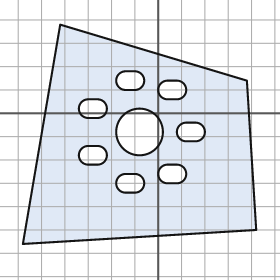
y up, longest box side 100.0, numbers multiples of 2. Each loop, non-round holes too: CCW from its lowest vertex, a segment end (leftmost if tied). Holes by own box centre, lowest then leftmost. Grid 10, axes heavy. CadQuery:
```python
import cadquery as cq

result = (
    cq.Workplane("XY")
    .moveTo(-58.0, -56.0)
    .lineTo(42.0, -50.0)
    .lineTo(38.0, 14.0)
    .lineTo(-42.0, 38.0)
    .close()
    .moveTo(-14.0, -34.0)
    .lineTo(-10.0, -34.0)
    .threePointArc((-6.0, -30.0), (-10.0, -26.0))
    .lineTo(-14.0, -26.0)
    .threePointArc((-18.0, -30.0), (-14.0, -34.0))
    .close()
    .moveTo(4.0, -30.0)
    .lineTo(8.0, -30.0)
    .threePointArc((12.0, -26.0), (8.0, -22.0))
    .lineTo(4.0, -22.0)
    .threePointArc((0.0, -26.0), (4.0, -30.0))
    .close()
    .moveTo(-30.0, -22.0)
    .lineTo(-26.0, -22.0)
    .threePointArc((-22.0, -18.0), (-26.0, -14.0))
    .lineTo(-30.0, -14.0)
    .threePointArc((-34.0, -18.0), (-30.0, -22.0))
    .close()
    .moveTo(-8.0, -8.0)
    .circle(10.0)
    .moveTo(12.0, -12.0)
    .lineTo(16.0, -12.0)
    .threePointArc((20.0, -8.0), (16.0, -4.0))
    .lineTo(12.0, -4.0)
    .threePointArc((8.0, -8.0), (12.0, -12.0))
    .close()
    .moveTo(-30.0, -2.0)
    .lineTo(-26.0, -2.0)
    .threePointArc((-22.0, 2.0), (-26.0, 6.0))
    .lineTo(-30.0, 6.0)
    .threePointArc((-34.0, 2.0), (-30.0, -2.0))
    .close()
    .moveTo(4.0, 6.0)
    .lineTo(8.0, 6.0)
    .threePointArc((12.0, 10.0), (8.0, 14.0))
    .lineTo(4.0, 14.0)
    .threePointArc((0.0, 10.0), (4.0, 6.0))
    .close()
    .moveTo(-14.0, 10.0)
    .lineTo(-10.0, 10.0)
    .threePointArc((-6.0, 14.0), (-10.0, 18.0))
    .lineTo(-14.0, 18.0)
    .threePointArc((-18.0, 14.0), (-14.0, 10.0))
    .close()
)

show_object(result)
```